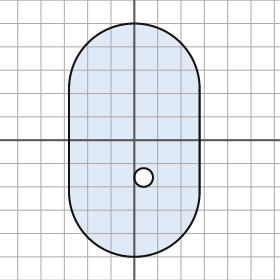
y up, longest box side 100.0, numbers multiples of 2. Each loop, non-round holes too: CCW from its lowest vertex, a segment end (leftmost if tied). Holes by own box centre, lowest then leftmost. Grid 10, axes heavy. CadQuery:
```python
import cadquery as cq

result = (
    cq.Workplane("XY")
    .moveTo(-28.0, -22.0)
    .threePointArc((0.0, -50.0), (28.0, -22.0))
    .lineTo(28.0, 22.0)
    .threePointArc((0.0, 50.0), (-28.0, 22.0))
    .close()
    .moveTo(4.0, -16.0)
    .circle(4.0)
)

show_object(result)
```